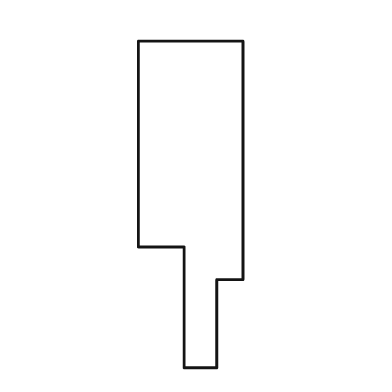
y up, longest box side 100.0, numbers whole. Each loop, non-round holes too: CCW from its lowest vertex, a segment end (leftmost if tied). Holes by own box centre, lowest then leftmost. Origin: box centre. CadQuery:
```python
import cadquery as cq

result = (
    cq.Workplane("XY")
    .moveTo(-2.0, -50.0)
    .lineTo(8.0, -50.0)
    .lineTo(8.0, -23.0)
    .lineTo(16.0, -23.0)
    .lineTo(16.0, 50.0)
    .lineTo(-16.0, 50.0)
    .lineTo(-16.0, -13.0)
    .lineTo(-2.0, -13.0)
    .close()
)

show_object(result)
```